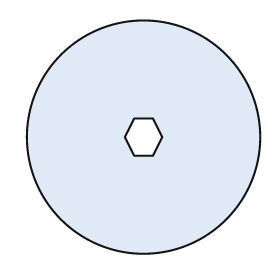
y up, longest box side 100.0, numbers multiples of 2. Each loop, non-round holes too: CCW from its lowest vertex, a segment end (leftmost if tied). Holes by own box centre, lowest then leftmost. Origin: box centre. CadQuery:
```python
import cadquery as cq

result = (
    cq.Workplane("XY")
    .moveTo(0.0, 0.0)
    .circle(50.0)
    .moveTo(-4.0, -8.0)
    .lineTo(4.0, -8.0)
    .lineTo(8.0, 0.0)
    .lineTo(4.0, 8.0)
    .lineTo(-4.0, 8.0)
    .lineTo(-8.0, 0.0)
    .close()
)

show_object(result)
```